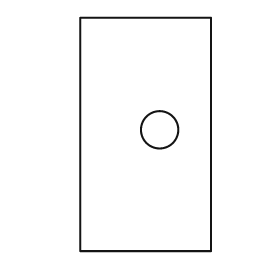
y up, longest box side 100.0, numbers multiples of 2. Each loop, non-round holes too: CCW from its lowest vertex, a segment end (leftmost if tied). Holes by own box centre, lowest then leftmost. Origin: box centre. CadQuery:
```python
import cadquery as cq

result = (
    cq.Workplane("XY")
    .moveTo(-28.0, -50.0)
    .lineTo(28.0, -50.0)
    .lineTo(28.0, 50.0)
    .lineTo(-28.0, 50.0)
    .close()
    .moveTo(6.0, 2.0)
    .circle(8.0)
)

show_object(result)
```